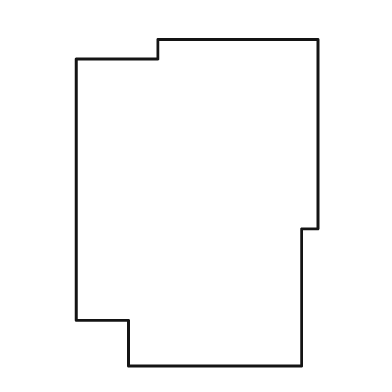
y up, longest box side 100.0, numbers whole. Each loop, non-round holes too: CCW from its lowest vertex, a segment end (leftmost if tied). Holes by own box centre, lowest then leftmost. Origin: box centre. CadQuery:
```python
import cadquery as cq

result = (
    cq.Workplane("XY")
    .moveTo(-21.0, -50.0)
    .lineTo(32.0, -50.0)
    .lineTo(32.0, -8.0)
    .lineTo(37.0, -8.0)
    .lineTo(37.0, 50.0)
    .lineTo(-12.0, 50.0)
    .lineTo(-12.0, 44.0)
    .lineTo(-37.0, 44.0)
    .lineTo(-37.0, -36.0)
    .lineTo(-21.0, -36.0)
    .close()
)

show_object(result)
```